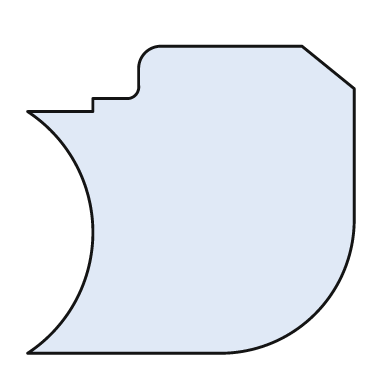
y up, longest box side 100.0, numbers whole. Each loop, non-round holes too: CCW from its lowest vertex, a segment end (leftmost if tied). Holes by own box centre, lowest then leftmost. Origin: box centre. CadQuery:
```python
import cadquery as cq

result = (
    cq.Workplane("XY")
    .moveTo(-50.0, -47.0)
    .lineTo(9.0, -47.0)
    .threePointArc((38.0, -35.0), (50.0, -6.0))
    .lineTo(50.0, 34.0)
    .lineTo(34.0, 47.0)
    .lineTo(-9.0, 47.0)
    .threePointArc((-14.0, 45.0), (-16.0, 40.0))
    .lineTo(-16.0, 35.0)
    .threePointArc((-17.0, 32.0), (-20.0, 31.0))
    .lineTo(-30.0, 31.0)
    .lineTo(-30.0, 27.0)
    .lineTo(-50.0, 27.0)
    .threePointArc((-30.0, -10.0), (-50.0, -47.0))
    .close()
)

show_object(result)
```